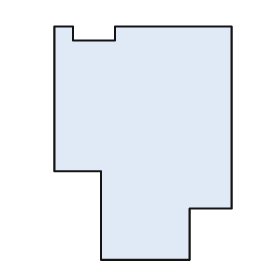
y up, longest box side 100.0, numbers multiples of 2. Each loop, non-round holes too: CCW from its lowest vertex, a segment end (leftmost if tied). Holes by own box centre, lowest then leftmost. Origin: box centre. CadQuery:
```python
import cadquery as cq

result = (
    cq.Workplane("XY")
    .moveTo(-18.0, -50.0)
    .lineTo(20.0, -50.0)
    .lineTo(20.0, -28.0)
    .lineTo(38.0, -28.0)
    .lineTo(38.0, 50.0)
    .lineTo(-12.0, 50.0)
    .lineTo(-12.0, 44.0)
    .lineTo(-30.0, 44.0)
    .lineTo(-30.0, 50.0)
    .lineTo(-38.0, 50.0)
    .lineTo(-38.0, -12.0)
    .lineTo(-18.0, -12.0)
    .close()
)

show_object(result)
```